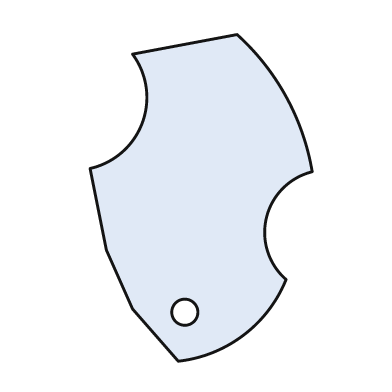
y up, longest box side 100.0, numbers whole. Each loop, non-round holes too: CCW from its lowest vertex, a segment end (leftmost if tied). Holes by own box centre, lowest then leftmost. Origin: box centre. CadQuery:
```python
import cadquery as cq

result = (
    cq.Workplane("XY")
    .moveTo(-7.0, -50.0)
    .threePointArc((13.0, -42.0), (26.0, -25.0))
    .threePointArc((20.0, -6.0), (34.0, 8.0))
    .threePointArc((26.0, 31.0), (11.0, 50.0))
    .lineTo(-21.0, 44.0)
    .threePointArc((-18.0, 23.0), (-34.0, 9.0))
    .lineTo(-29.0, -16.0)
    .lineTo(-21.0, -34.0)
    .close()
    .moveTo(-5.0, -35.0)
    .circle(4.0)
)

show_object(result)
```